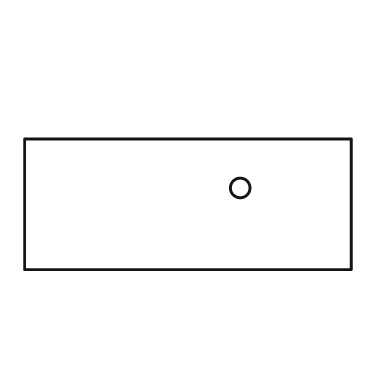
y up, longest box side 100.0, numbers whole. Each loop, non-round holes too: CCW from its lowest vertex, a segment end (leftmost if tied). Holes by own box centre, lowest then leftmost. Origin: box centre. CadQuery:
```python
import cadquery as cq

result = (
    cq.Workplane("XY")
    .moveTo(-50.0, -20.0)
    .lineTo(50.0, -20.0)
    .lineTo(50.0, 20.0)
    .lineTo(-50.0, 20.0)
    .close()
    .moveTo(16.0, 5.0)
    .circle(3.0)
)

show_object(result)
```